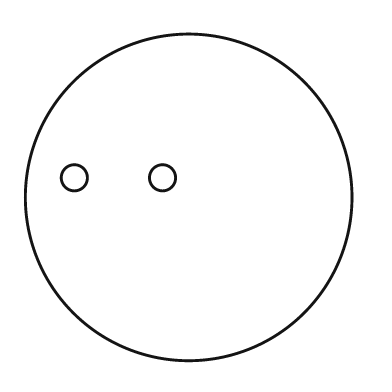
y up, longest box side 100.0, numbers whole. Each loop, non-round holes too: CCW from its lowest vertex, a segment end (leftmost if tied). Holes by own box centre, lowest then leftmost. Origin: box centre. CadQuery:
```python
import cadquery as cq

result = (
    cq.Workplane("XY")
    .moveTo(0.0, 0.0)
    .circle(50.0)
    .moveTo(-35.0, 6.0)
    .circle(4.0)
    .moveTo(-8.0, 6.0)
    .circle(4.0)
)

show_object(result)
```